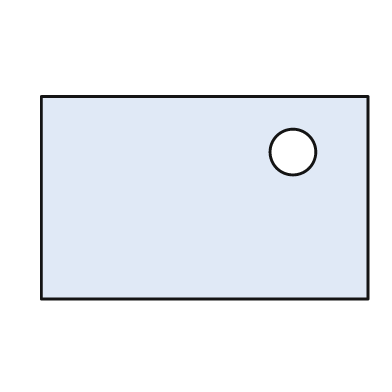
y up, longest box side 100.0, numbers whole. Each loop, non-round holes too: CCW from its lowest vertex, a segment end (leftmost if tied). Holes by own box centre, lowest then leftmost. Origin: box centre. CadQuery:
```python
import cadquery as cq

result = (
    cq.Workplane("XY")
    .moveTo(-50.0, -31.0)
    .lineTo(50.0, -31.0)
    .lineTo(50.0, 31.0)
    .lineTo(-50.0, 31.0)
    .close()
    .moveTo(27.0, 14.0)
    .circle(7.0)
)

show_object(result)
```